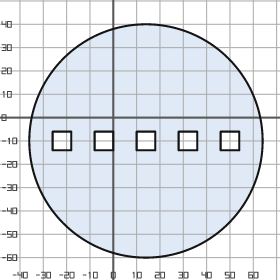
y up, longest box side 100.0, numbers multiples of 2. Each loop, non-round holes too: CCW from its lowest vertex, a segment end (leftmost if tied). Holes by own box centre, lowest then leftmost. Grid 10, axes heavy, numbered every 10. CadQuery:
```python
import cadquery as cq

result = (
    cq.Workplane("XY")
    .moveTo(14.0, -10.0)
    .circle(50.0)
    .moveTo(-26.0, -14.0)
    .lineTo(-18.0, -14.0)
    .lineTo(-18.0, -6.0)
    .lineTo(-26.0, -6.0)
    .close()
    .moveTo(-8.0, -14.0)
    .lineTo(0.0, -14.0)
    .lineTo(0.0, -6.0)
    .lineTo(-8.0, -6.0)
    .close()
    .moveTo(10.0, -14.0)
    .lineTo(18.0, -14.0)
    .lineTo(18.0, -6.0)
    .lineTo(10.0, -6.0)
    .close()
    .moveTo(28.0, -14.0)
    .lineTo(36.0, -14.0)
    .lineTo(36.0, -6.0)
    .lineTo(28.0, -6.0)
    .close()
    .moveTo(46.0, -14.0)
    .lineTo(54.0, -14.0)
    .lineTo(54.0, -6.0)
    .lineTo(46.0, -6.0)
    .close()
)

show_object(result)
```